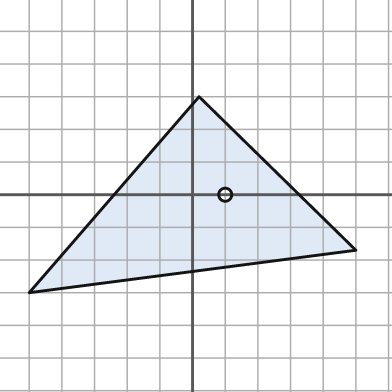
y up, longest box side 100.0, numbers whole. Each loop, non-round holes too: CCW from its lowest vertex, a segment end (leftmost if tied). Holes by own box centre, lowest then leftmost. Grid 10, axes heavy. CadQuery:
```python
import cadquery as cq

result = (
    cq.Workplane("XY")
    .moveTo(-50.0, -30.0)
    .lineTo(50.0, -17.0)
    .lineTo(2.0, 30.0)
    .close()
    .moveTo(10.0, 0.0)
    .circle(2.0)
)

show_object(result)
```